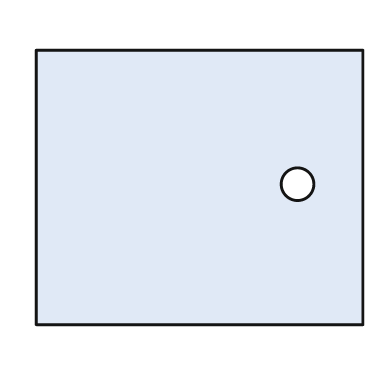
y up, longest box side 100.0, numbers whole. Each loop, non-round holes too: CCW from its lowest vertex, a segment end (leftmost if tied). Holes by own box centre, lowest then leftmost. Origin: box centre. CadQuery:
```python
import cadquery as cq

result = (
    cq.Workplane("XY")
    .moveTo(-50.0, -42.0)
    .lineTo(50.0, -42.0)
    .lineTo(50.0, 42.0)
    .lineTo(-50.0, 42.0)
    .close()
    .moveTo(30.0, 1.0)
    .circle(5.0)
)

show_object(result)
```